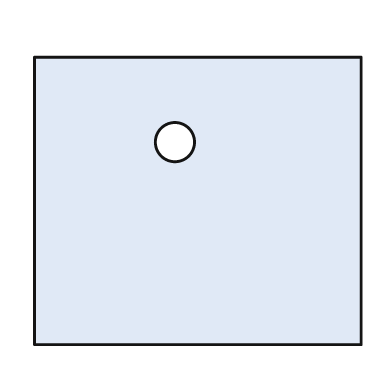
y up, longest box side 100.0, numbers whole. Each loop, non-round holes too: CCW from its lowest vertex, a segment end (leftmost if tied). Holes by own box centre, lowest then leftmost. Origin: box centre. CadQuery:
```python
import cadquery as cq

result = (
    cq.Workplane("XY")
    .moveTo(-50.0, -44.0)
    .lineTo(50.0, -44.0)
    .lineTo(50.0, 44.0)
    .lineTo(-50.0, 44.0)
    .close()
    .moveTo(-7.0, 18.0)
    .circle(6.0)
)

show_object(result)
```